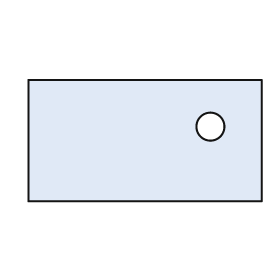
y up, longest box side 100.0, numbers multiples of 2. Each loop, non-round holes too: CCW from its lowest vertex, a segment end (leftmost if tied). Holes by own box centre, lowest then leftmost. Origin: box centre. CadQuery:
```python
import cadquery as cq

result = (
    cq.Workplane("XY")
    .moveTo(-50.0, -26.0)
    .lineTo(50.0, -26.0)
    .lineTo(50.0, 26.0)
    .lineTo(-50.0, 26.0)
    .close()
    .moveTo(28.0, 6.0)
    .circle(6.0)
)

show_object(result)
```